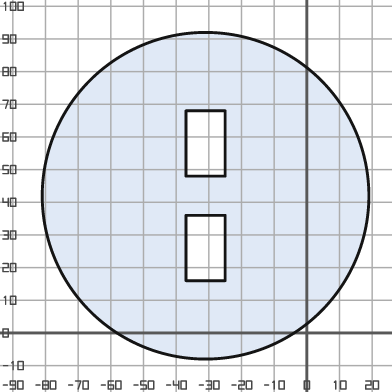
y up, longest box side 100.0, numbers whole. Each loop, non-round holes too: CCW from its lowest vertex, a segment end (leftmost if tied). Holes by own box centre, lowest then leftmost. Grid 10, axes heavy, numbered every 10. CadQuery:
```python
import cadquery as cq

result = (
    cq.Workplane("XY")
    .moveTo(-31.0, 42.0)
    .circle(50.0)
    .moveTo(-37.0, 16.0)
    .lineTo(-25.0, 16.0)
    .lineTo(-25.0, 36.0)
    .lineTo(-37.0, 36.0)
    .close()
    .moveTo(-37.0, 48.0)
    .lineTo(-25.0, 48.0)
    .lineTo(-25.0, 68.0)
    .lineTo(-37.0, 68.0)
    .close()
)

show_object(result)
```